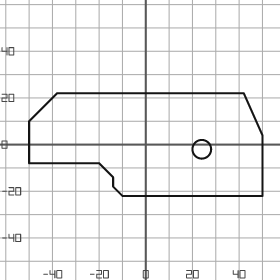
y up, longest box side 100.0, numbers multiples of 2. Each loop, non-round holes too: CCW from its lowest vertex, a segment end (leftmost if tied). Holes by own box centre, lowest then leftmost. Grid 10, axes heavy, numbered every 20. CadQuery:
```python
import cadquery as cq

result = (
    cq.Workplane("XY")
    .moveTo(-10.0, -22.0)
    .lineTo(50.0, -22.0)
    .lineTo(50.0, 4.0)
    .lineTo(42.0, 22.0)
    .lineTo(-38.0, 22.0)
    .lineTo(-50.0, 10.0)
    .lineTo(-50.0, -8.0)
    .lineTo(-20.0, -8.0)
    .lineTo(-14.0, -14.0)
    .lineTo(-14.0, -18.0)
    .close()
    .moveTo(24.0, -2.0)
    .circle(4.0)
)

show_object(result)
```